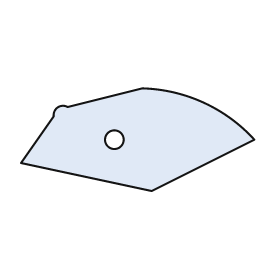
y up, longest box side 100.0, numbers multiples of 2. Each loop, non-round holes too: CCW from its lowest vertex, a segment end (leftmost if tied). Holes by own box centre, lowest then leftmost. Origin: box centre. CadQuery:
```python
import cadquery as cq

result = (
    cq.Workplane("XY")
    .moveTo(6.0, -22.0)
    .lineTo(50.0, 0.0)
    .threePointArc((28.0, 16.0), (2.0, 22.0))
    .lineTo(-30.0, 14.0)
    .threePointArc((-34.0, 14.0), (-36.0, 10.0))
    .lineTo(-50.0, -10.0)
    .close()
    .moveTo(-10.0, 0.0)
    .circle(4.0)
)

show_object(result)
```